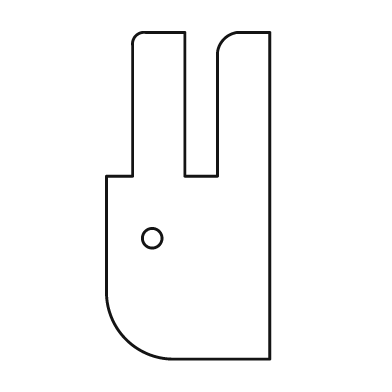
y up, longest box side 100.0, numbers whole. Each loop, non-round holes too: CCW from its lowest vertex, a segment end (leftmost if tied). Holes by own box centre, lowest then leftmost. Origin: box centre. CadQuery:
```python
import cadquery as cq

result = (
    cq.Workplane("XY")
    .moveTo(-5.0, -50.0)
    .lineTo(25.0, -50.0)
    .lineTo(25.0, 50.0)
    .lineTo(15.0, 50.0)
    .threePointArc((11.0, 48.0), (9.0, 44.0))
    .lineTo(9.0, 6.0)
    .lineTo(-1.0, 6.0)
    .lineTo(-1.0, 50.0)
    .lineTo(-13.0, 50.0)
    .threePointArc((-16.0, 49.0), (-17.0, 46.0))
    .lineTo(-17.0, 6.0)
    .lineTo(-25.0, 6.0)
    .lineTo(-25.0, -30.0)
    .threePointArc((-19.0, -44.0), (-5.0, -50.0))
    .close()
    .moveTo(-11.0, -13.0)
    .circle(3.0)
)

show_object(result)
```